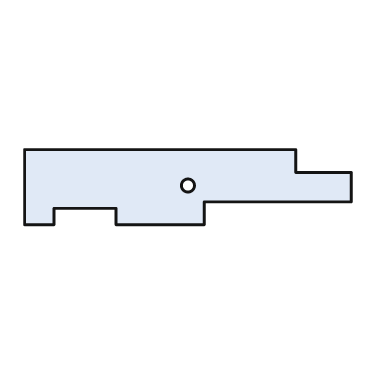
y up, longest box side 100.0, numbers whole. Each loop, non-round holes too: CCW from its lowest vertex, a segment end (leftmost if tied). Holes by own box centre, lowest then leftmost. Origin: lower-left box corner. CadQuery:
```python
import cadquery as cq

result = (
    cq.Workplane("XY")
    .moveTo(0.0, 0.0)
    .lineTo(9.0, 0.0)
    .lineTo(9.0, 5.0)
    .lineTo(28.0, 5.0)
    .lineTo(28.0, 0.0)
    .lineTo(55.0, 0.0)
    .lineTo(55.0, 7.0)
    .lineTo(100.0, 7.0)
    .lineTo(100.0, 16.0)
    .lineTo(83.0, 16.0)
    .lineTo(83.0, 23.0)
    .lineTo(0.0, 23.0)
    .close()
    .moveTo(50.0, 12.0)
    .circle(2.0)
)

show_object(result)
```